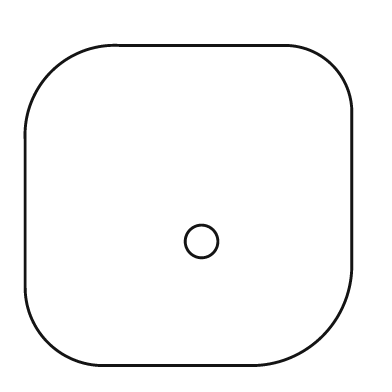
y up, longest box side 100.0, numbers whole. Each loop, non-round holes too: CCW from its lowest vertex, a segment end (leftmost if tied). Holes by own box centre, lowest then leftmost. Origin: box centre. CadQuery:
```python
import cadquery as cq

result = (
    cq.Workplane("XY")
    .moveTo(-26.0, -49.0)
    .lineTo(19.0, -49.0)
    .threePointArc((41.0, -40.0), (50.0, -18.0))
    .lineTo(50.0, 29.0)
    .threePointArc((44.0, 43.0), (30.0, 49.0))
    .lineTo(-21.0, 49.0)
    .threePointArc((-42.0, 41.0), (-50.0, 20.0))
    .lineTo(-50.0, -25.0)
    .threePointArc((-43.0, -42.0), (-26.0, -49.0))
    .close()
    .moveTo(4.0, -11.0)
    .circle(5.0)
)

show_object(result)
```